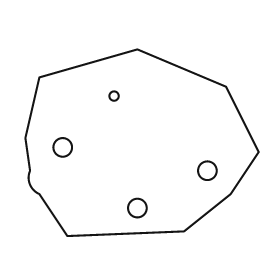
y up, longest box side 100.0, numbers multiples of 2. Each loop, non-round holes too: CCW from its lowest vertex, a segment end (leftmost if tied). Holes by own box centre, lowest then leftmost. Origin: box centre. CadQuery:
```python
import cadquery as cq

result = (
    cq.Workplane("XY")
    .moveTo(-32.0, -40.0)
    .lineTo(18.0, -38.0)
    .lineTo(38.0, -22.0)
    .lineTo(50.0, -4.0)
    .lineTo(36.0, 24.0)
    .lineTo(-2.0, 40.0)
    .lineTo(-44.0, 28.0)
    .lineTo(-50.0, 2.0)
    .lineTo(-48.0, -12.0)
    .threePointArc((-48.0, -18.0), (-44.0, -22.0))
    .close()
    .moveTo(-2.0, -28.0)
    .circle(4.0)
    .moveTo(28.0, -12.0)
    .circle(4.0)
    .moveTo(-34.0, -2.0)
    .circle(4.0)
    .moveTo(-12.0, 20.0)
    .circle(2.0)
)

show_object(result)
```